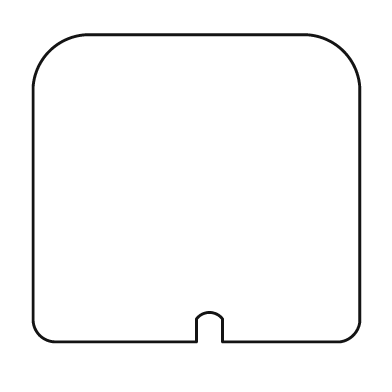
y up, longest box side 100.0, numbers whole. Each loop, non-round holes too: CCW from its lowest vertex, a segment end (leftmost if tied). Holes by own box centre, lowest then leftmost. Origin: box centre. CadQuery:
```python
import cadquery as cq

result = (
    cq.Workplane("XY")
    .moveTo(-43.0, -47.0)
    .lineTo(0.0, -47.0)
    .lineTo(0.0, -40.0)
    .threePointArc((4.0, -38.0), (8.0, -40.0))
    .lineTo(8.0, -47.0)
    .lineTo(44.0, -47.0)
    .threePointArc((48.0, -45.0), (50.0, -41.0))
    .lineTo(50.0, 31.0)
    .threePointArc((45.0, 42.0), (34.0, 47.0))
    .lineTo(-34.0, 47.0)
    .threePointArc((-45.0, 42.0), (-50.0, 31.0))
    .lineTo(-50.0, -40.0)
    .threePointArc((-48.0, -45.0), (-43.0, -47.0))
    .close()
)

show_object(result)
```